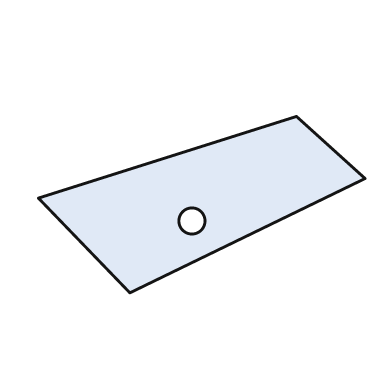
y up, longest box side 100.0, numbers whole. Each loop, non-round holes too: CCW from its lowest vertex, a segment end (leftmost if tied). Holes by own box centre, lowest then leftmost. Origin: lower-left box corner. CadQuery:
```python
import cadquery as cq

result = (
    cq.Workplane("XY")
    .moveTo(28.0, 0.0)
    .lineTo(100.0, 35.0)
    .lineTo(79.0, 54.0)
    .lineTo(0.0, 29.0)
    .close()
    .moveTo(47.0, 22.0)
    .circle(4.0)
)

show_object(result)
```